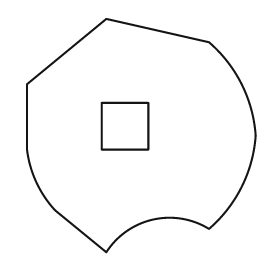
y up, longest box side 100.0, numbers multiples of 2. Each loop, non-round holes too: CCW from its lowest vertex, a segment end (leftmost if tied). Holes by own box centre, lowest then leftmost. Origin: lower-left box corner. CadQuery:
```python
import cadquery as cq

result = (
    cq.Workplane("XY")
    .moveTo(34.0, 0.0)
    .threePointArc((54.0, 14.0), (78.0, 10.0))
    .threePointArc((92.0, 28.0), (98.0, 50.0))
    .threePointArc((92.0, 72.0), (78.0, 90.0))
    .lineTo(34.0, 100.0)
    .lineTo(0.0, 72.0)
    .lineTo(0.0, 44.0)
    .threePointArc((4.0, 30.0), (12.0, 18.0))
    .close()
    .moveTo(32.0, 44.0)
    .lineTo(52.0, 44.0)
    .lineTo(52.0, 64.0)
    .lineTo(32.0, 64.0)
    .close()
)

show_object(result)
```